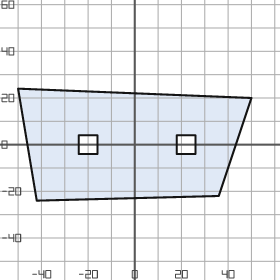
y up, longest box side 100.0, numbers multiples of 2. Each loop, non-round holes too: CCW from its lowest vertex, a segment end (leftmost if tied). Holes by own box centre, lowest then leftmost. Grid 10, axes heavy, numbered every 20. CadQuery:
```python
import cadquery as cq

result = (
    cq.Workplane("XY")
    .moveTo(-42.0, -24.0)
    .lineTo(36.0, -22.0)
    .lineTo(50.0, 20.0)
    .lineTo(-50.0, 24.0)
    .close()
    .moveTo(-24.0, -4.0)
    .lineTo(-16.0, -4.0)
    .lineTo(-16.0, 4.0)
    .lineTo(-24.0, 4.0)
    .close()
    .moveTo(18.0, -4.0)
    .lineTo(26.0, -4.0)
    .lineTo(26.0, 4.0)
    .lineTo(18.0, 4.0)
    .close()
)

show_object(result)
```